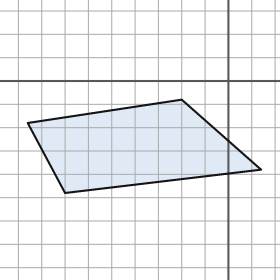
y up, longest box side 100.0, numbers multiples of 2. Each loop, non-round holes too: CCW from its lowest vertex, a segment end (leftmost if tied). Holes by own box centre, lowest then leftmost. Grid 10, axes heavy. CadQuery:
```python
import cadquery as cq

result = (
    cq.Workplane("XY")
    .moveTo(-70.0, -48.0)
    .lineTo(14.0, -38.0)
    .lineTo(-20.0, -8.0)
    .lineTo(-86.0, -18.0)
    .close()
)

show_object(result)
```